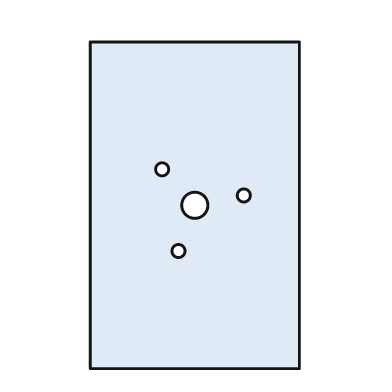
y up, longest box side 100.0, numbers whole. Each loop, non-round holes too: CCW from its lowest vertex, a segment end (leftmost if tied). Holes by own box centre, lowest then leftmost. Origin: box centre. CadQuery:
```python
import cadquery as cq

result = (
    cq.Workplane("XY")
    .moveTo(-32.0, -50.0)
    .lineTo(32.0, -50.0)
    .lineTo(32.0, 50.0)
    .lineTo(-32.0, 50.0)
    .close()
    .moveTo(-5.0, -14.0)
    .circle(2.0)
    .moveTo(0.0, 0.0)
    .circle(4.0)
    .moveTo(15.0, 3.0)
    .circle(2.0)
    .moveTo(-10.0, 11.0)
    .circle(2.0)
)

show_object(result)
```